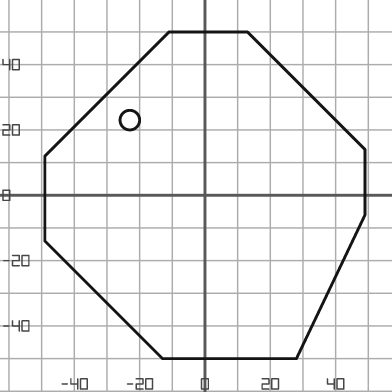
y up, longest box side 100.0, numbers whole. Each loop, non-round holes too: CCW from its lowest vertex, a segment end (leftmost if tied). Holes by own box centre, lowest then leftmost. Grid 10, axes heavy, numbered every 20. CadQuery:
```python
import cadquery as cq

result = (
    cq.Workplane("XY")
    .moveTo(-13.0, -50.0)
    .lineTo(28.0, -50.0)
    .lineTo(49.0, -6.0)
    .lineTo(49.0, 14.0)
    .lineTo(13.0, 50.0)
    .lineTo(-11.0, 50.0)
    .lineTo(-49.0, 12.0)
    .lineTo(-49.0, -14.0)
    .close()
    .moveTo(-23.0, 23.0)
    .circle(3.0)
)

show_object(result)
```